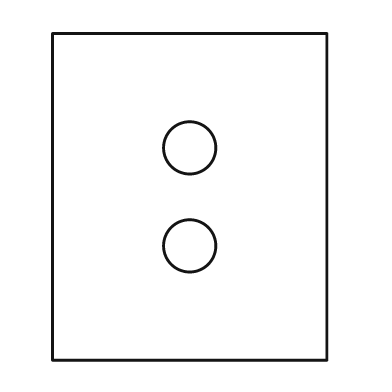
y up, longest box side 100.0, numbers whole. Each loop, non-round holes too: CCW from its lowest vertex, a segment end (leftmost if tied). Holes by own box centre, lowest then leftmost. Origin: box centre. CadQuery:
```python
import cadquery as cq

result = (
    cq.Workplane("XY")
    .moveTo(-42.0, -50.0)
    .lineTo(42.0, -50.0)
    .lineTo(42.0, 50.0)
    .lineTo(-42.0, 50.0)
    .close()
    .moveTo(0.0, -15.0)
    .circle(8.0)
    .moveTo(0.0, 15.0)
    .circle(8.0)
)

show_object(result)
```